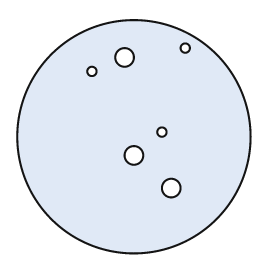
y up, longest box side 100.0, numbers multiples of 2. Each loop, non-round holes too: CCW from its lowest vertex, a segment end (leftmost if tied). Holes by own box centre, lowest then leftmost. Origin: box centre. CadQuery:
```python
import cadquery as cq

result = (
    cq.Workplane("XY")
    .moveTo(0.0, 0.0)
    .circle(50.0)
    .moveTo(16.0, -22.0)
    .circle(4.0)
    .moveTo(0.0, -8.0)
    .circle(4.0)
    .moveTo(12.0, 2.0)
    .circle(2.0)
    .moveTo(-18.0, 28.0)
    .circle(2.0)
    .moveTo(-4.0, 34.0)
    .circle(4.0)
    .moveTo(22.0, 38.0)
    .circle(2.0)
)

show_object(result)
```